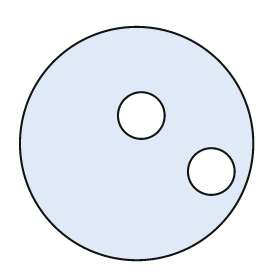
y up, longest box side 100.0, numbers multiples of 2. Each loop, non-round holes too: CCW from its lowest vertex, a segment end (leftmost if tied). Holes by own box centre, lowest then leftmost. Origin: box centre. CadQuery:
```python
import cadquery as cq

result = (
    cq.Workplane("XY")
    .moveTo(0.0, 0.0)
    .circle(50.0)
    .moveTo(32.0, -12.0)
    .circle(10.0)
    .moveTo(2.0, 12.0)
    .circle(10.0)
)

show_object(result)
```